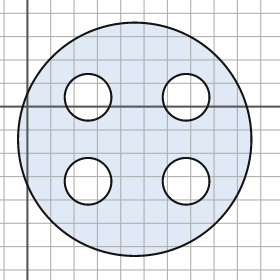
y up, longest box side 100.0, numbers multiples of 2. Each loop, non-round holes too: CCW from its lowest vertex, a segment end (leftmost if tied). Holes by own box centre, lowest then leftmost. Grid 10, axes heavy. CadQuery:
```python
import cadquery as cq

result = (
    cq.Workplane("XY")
    .moveTo(46.0, -14.0)
    .circle(50.0)
    .moveTo(26.0, -32.0)
    .circle(10.0)
    .moveTo(68.0, -32.0)
    .circle(10.0)
    .moveTo(26.0, 4.0)
    .circle(10.0)
    .moveTo(68.0, 4.0)
    .circle(10.0)
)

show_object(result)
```